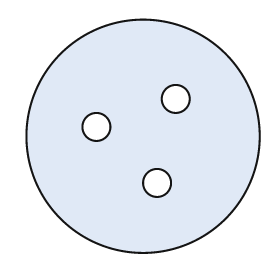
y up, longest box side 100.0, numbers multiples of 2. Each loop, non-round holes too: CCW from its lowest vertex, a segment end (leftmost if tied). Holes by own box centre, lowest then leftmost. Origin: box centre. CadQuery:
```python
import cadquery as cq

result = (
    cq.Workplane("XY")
    .moveTo(0.0, 0.0)
    .circle(50.0)
    .moveTo(6.0, -20.0)
    .circle(6.0)
    .moveTo(-20.0, 4.0)
    .circle(6.0)
    .moveTo(14.0, 16.0)
    .circle(6.0)
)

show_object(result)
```